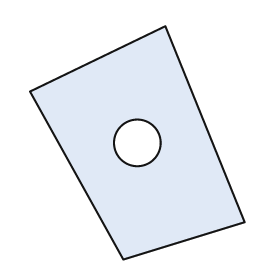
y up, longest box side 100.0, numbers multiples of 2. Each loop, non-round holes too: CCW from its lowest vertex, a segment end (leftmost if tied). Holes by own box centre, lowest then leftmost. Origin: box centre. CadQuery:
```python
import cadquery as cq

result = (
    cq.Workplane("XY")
    .moveTo(-6.0, -50.0)
    .lineTo(46.0, -34.0)
    .lineTo(12.0, 50.0)
    .lineTo(-46.0, 22.0)
    .close()
    .moveTo(0.0, 0.0)
    .circle(10.0)
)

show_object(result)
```